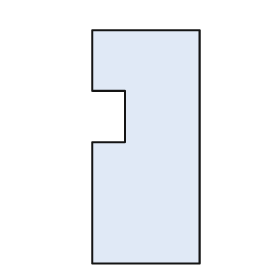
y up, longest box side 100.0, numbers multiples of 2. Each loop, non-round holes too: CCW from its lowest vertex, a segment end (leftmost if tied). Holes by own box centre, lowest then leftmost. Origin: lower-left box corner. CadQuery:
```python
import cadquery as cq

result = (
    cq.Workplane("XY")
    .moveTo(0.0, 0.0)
    .lineTo(46.0, 0.0)
    .lineTo(46.0, 100.0)
    .lineTo(0.0, 100.0)
    .lineTo(0.0, 74.0)
    .lineTo(14.0, 74.0)
    .lineTo(14.0, 52.0)
    .lineTo(0.0, 52.0)
    .close()
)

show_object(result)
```